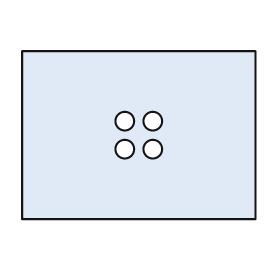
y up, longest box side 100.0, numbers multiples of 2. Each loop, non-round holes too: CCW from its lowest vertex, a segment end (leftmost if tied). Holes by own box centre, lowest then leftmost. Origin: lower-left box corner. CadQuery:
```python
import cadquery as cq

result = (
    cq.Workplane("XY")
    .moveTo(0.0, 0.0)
    .lineTo(100.0, 0.0)
    .lineTo(100.0, 72.0)
    .lineTo(0.0, 72.0)
    .close()
    .moveTo(44.0, 30.0)
    .circle(4.0)
    .moveTo(56.0, 30.0)
    .circle(4.0)
    .moveTo(44.0, 42.0)
    .circle(4.0)
    .moveTo(56.0, 42.0)
    .circle(4.0)
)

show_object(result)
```